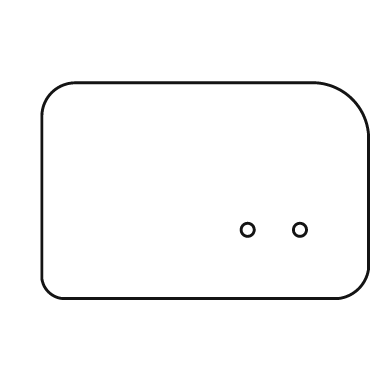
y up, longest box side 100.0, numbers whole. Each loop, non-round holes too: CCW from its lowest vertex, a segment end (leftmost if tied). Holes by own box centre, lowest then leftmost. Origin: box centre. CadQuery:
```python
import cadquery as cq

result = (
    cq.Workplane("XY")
    .moveTo(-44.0, -33.0)
    .lineTo(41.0, -33.0)
    .threePointArc((47.0, -30.0), (50.0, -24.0))
    .lineTo(50.0, 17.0)
    .threePointArc((45.0, 28.0), (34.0, 33.0))
    .lineTo(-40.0, 33.0)
    .threePointArc((-47.0, 30.0), (-50.0, 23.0))
    .lineTo(-50.0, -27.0)
    .threePointArc((-48.0, -31.0), (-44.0, -33.0))
    .close()
    .moveTo(13.0, -12.0)
    .circle(2.0)
    .moveTo(29.0, -12.0)
    .circle(2.0)
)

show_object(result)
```